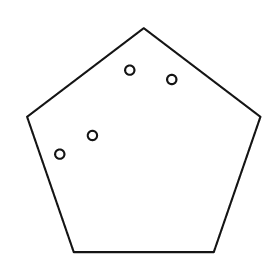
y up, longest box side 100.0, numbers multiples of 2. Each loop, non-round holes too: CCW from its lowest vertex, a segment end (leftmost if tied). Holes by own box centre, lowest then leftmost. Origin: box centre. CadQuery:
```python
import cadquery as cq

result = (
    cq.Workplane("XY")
    .moveTo(-30.0, -48.0)
    .lineTo(30.0, -48.0)
    .lineTo(50.0, 10.0)
    .lineTo(0.0, 48.0)
    .lineTo(-50.0, 10.0)
    .close()
    .moveTo(-36.0, -6.0)
    .circle(2.0)
    .moveTo(-22.0, 2.0)
    .circle(2.0)
    .moveTo(12.0, 26.0)
    .circle(2.0)
    .moveTo(-6.0, 30.0)
    .circle(2.0)
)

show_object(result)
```